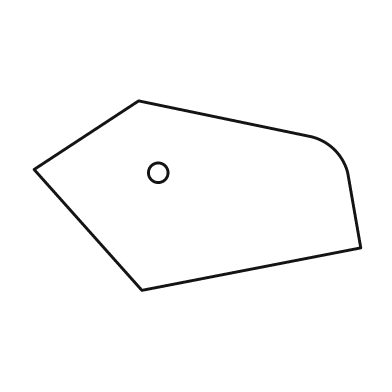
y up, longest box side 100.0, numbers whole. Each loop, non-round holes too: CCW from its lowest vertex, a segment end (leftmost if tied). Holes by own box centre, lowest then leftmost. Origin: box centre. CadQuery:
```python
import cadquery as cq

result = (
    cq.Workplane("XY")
    .moveTo(-17.0, -29.0)
    .lineTo(50.0, -16.0)
    .lineTo(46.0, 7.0)
    .threePointArc((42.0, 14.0), (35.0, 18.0))
    .lineTo(-18.0, 29.0)
    .lineTo(-50.0, 8.0)
    .close()
    .moveTo(-12.0, 7.0)
    .circle(3.0)
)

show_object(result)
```